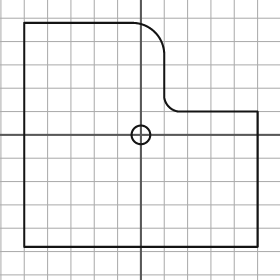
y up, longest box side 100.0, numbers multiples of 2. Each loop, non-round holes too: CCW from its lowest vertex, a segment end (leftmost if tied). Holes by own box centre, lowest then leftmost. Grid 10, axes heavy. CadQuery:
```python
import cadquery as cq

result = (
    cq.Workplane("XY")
    .moveTo(-50.0, -48.0)
    .lineTo(50.0, -48.0)
    .lineTo(50.0, 10.0)
    .lineTo(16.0, 10.0)
    .threePointArc((12.0, 12.0), (10.0, 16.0))
    .lineTo(10.0, 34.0)
    .threePointArc((6.0, 44.0), (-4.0, 48.0))
    .lineTo(-50.0, 48.0)
    .close()
    .moveTo(0.0, 0.0)
    .circle(4.0)
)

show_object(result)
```